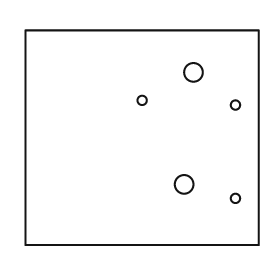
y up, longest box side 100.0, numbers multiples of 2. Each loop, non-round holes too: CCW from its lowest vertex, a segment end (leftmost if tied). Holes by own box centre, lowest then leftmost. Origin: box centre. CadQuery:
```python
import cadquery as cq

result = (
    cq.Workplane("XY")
    .moveTo(-50.0, -46.0)
    .lineTo(50.0, -46.0)
    .lineTo(50.0, 46.0)
    .lineTo(-50.0, 46.0)
    .close()
    .moveTo(40.0, -26.0)
    .circle(2.0)
    .moveTo(18.0, -20.0)
    .circle(4.0)
    .moveTo(40.0, 14.0)
    .circle(2.0)
    .moveTo(0.0, 16.0)
    .circle(2.0)
    .moveTo(22.0, 28.0)
    .circle(4.0)
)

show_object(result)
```